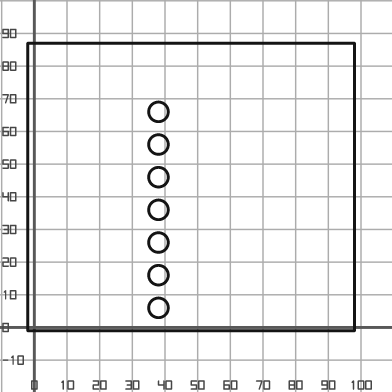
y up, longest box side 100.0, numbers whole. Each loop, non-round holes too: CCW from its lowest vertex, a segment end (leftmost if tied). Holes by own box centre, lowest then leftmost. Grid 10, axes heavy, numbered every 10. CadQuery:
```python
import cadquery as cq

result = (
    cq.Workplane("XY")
    .moveTo(-2.0, -1.0)
    .lineTo(98.0, -1.0)
    .lineTo(98.0, 87.0)
    .lineTo(-2.0, 87.0)
    .close()
    .moveTo(38.0, 6.0)
    .circle(3.0)
    .moveTo(38.0, 16.0)
    .circle(3.0)
    .moveTo(38.0, 26.0)
    .circle(3.0)
    .moveTo(38.0, 36.0)
    .circle(3.0)
    .moveTo(38.0, 46.0)
    .circle(3.0)
    .moveTo(38.0, 56.0)
    .circle(3.0)
    .moveTo(38.0, 66.0)
    .circle(3.0)
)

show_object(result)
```